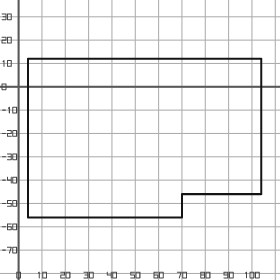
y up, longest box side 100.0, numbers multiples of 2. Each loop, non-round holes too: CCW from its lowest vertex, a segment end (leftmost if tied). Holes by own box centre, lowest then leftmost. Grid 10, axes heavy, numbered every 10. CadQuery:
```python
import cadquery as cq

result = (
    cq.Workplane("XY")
    .moveTo(4.0, -56.0)
    .lineTo(70.0, -56.0)
    .lineTo(70.0, -46.0)
    .lineTo(104.0, -46.0)
    .lineTo(104.0, 12.0)
    .lineTo(4.0, 12.0)
    .close()
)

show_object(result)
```